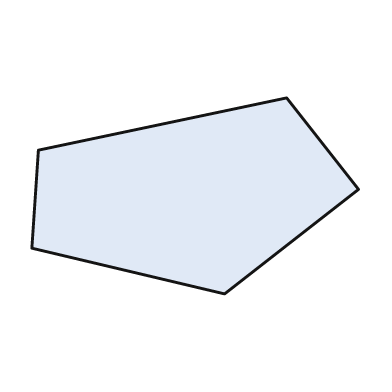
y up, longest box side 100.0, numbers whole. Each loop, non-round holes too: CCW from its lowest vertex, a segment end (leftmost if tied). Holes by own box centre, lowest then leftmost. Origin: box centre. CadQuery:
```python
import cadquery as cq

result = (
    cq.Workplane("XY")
    .moveTo(9.0, -30.0)
    .lineTo(50.0, 2.0)
    .lineTo(28.0, 30.0)
    .lineTo(-48.0, 14.0)
    .lineTo(-50.0, -16.0)
    .close()
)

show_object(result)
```